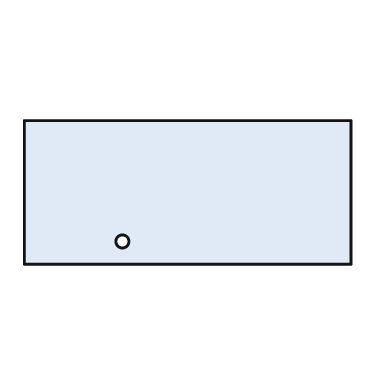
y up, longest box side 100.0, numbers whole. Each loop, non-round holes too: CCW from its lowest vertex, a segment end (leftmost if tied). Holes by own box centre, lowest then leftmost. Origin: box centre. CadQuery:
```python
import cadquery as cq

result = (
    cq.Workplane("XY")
    .moveTo(-50.0, -22.0)
    .lineTo(50.0, -22.0)
    .lineTo(50.0, 22.0)
    .lineTo(-50.0, 22.0)
    .close()
    .moveTo(-20.0, -15.0)
    .circle(2.0)
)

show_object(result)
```